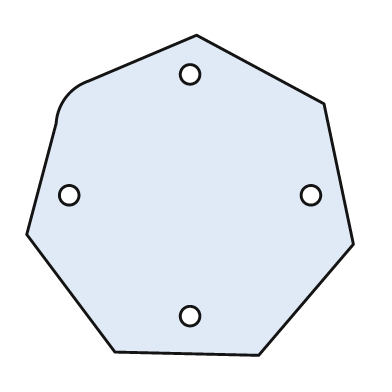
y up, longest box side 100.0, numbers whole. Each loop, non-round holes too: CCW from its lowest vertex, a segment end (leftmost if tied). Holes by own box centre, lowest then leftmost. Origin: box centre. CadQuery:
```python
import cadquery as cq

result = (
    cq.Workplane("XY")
    .moveTo(21.0, -49.0)
    .lineTo(50.0, -15.0)
    .lineTo(41.0, 28.0)
    .lineTo(2.0, 49.0)
    .lineTo(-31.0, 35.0)
    .threePointArc((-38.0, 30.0), (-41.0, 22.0))
    .lineTo(-50.0, -12.0)
    .lineTo(-23.0, -48.0)
    .close()
    .moveTo(0.0, -37.0)
    .circle(3.0)
    .moveTo(-37.0, 0.0)
    .circle(3.0)
    .moveTo(37.0, 0.0)
    .circle(3.0)
    .moveTo(0.0, 37.0)
    .circle(3.0)
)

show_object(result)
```